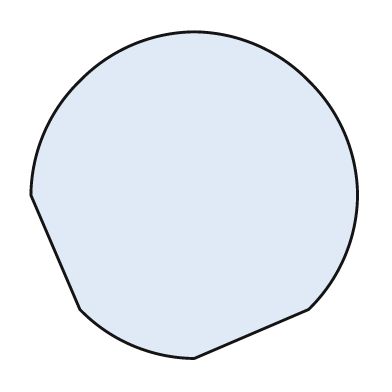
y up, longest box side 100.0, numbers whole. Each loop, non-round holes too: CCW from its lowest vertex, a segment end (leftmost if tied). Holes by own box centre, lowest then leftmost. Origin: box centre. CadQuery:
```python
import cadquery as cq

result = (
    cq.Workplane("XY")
    .moveTo(0.0, -50.0)
    .lineTo(35.0, -35.0)
    .threePointArc((46.0, -19.0), (50.0, 0.0))
    .threePointArc((46.0, 19.0), (35.0, 35.0))
    .threePointArc((19.0, 46.0), (0.0, 50.0))
    .threePointArc((-19.0, 46.0), (-35.0, 35.0))
    .threePointArc((-46.0, 19.0), (-50.0, 0.0))
    .lineTo(-35.0, -35.0)
    .threePointArc((-19.0, -46.0), (0.0, -50.0))
    .close()
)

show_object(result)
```